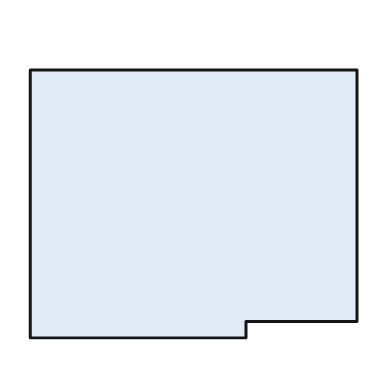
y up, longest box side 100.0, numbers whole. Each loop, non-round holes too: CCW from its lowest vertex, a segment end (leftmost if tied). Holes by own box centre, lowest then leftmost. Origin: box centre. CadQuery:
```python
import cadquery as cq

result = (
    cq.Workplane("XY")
    .moveTo(-50.0, -41.0)
    .lineTo(16.0, -41.0)
    .lineTo(16.0, -36.0)
    .lineTo(50.0, -36.0)
    .lineTo(50.0, 41.0)
    .lineTo(-50.0, 41.0)
    .close()
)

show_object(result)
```